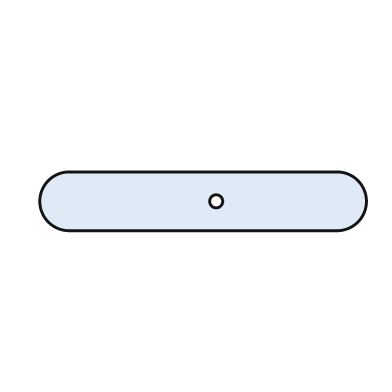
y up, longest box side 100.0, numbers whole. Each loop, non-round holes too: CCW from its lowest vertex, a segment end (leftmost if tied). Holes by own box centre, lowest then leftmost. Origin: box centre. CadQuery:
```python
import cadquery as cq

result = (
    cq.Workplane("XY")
    .moveTo(-41.0, -9.0)
    .lineTo(41.0, -9.0)
    .threePointArc((50.0, 0.0), (41.0, 9.0))
    .lineTo(-41.0, 9.0)
    .threePointArc((-50.0, 0.0), (-41.0, -9.0))
    .close()
    .moveTo(4.0, 0.0)
    .circle(2.0)
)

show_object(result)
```